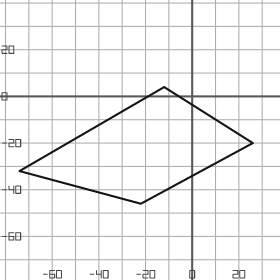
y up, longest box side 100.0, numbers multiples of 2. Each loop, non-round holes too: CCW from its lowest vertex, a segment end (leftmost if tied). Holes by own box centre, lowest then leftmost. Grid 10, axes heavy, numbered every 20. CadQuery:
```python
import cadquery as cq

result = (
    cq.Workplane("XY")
    .moveTo(-22.0, -46.0)
    .lineTo(26.0, -20.0)
    .lineTo(-12.0, 4.0)
    .lineTo(-74.0, -32.0)
    .close()
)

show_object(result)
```